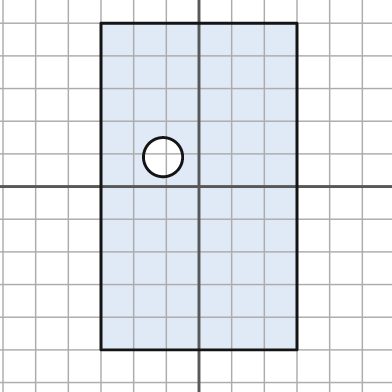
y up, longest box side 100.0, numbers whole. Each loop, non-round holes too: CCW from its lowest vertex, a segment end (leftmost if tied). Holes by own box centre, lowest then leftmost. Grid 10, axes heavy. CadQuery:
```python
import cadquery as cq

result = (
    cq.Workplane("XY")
    .moveTo(-30.0, -50.0)
    .lineTo(30.0, -50.0)
    .lineTo(30.0, 50.0)
    .lineTo(-30.0, 50.0)
    .close()
    .moveTo(-11.0, 9.0)
    .circle(6.0)
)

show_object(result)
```